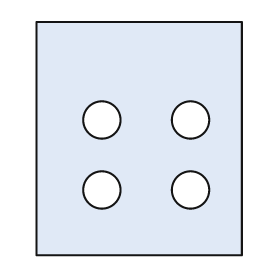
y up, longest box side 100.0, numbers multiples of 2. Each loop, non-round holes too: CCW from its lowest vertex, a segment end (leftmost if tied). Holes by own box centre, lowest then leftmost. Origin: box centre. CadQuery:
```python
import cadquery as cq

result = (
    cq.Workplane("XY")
    .moveTo(-44.0, -50.0)
    .lineTo(44.0, -50.0)
    .lineTo(44.0, 50.0)
    .lineTo(-44.0, 50.0)
    .close()
    .moveTo(-16.0, -22.0)
    .circle(8.0)
    .moveTo(22.0, -22.0)
    .circle(8.0)
    .moveTo(-16.0, 8.0)
    .circle(8.0)
    .moveTo(22.0, 8.0)
    .circle(8.0)
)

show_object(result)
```